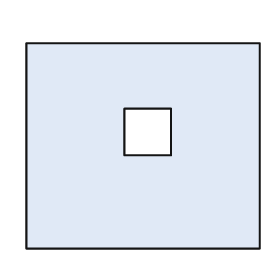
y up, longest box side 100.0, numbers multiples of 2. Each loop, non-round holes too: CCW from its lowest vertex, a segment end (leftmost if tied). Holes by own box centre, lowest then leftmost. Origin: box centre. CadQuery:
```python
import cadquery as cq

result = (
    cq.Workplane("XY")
    .moveTo(-50.0, -44.0)
    .lineTo(50.0, -44.0)
    .lineTo(50.0, 44.0)
    .lineTo(-50.0, 44.0)
    .close()
    .moveTo(-8.0, -4.0)
    .lineTo(12.0, -4.0)
    .lineTo(12.0, 16.0)
    .lineTo(-8.0, 16.0)
    .close()
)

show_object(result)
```